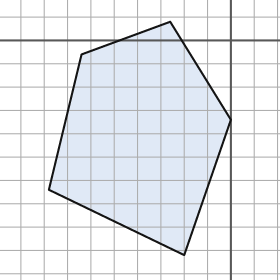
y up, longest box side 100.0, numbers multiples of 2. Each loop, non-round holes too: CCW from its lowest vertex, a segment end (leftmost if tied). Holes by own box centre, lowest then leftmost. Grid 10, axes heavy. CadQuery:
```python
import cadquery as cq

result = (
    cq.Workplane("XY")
    .moveTo(-20.0, -92.0)
    .lineTo(0.0, -34.0)
    .lineTo(-26.0, 8.0)
    .lineTo(-64.0, -6.0)
    .lineTo(-78.0, -64.0)
    .close()
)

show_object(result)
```